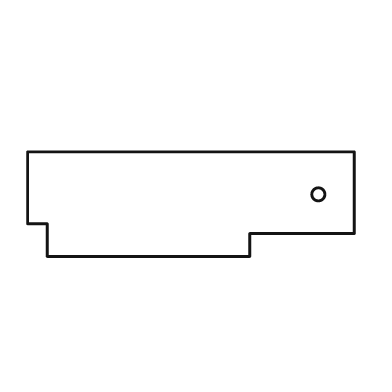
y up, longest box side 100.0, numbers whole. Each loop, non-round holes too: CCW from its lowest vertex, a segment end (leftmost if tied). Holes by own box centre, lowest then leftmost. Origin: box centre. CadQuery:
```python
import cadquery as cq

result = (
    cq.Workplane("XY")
    .moveTo(-44.0, -16.0)
    .lineTo(18.0, -16.0)
    .lineTo(18.0, -9.0)
    .lineTo(50.0, -9.0)
    .lineTo(50.0, 16.0)
    .lineTo(-50.0, 16.0)
    .lineTo(-50.0, -6.0)
    .lineTo(-44.0, -6.0)
    .close()
    .moveTo(39.0, 3.0)
    .circle(2.0)
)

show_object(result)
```